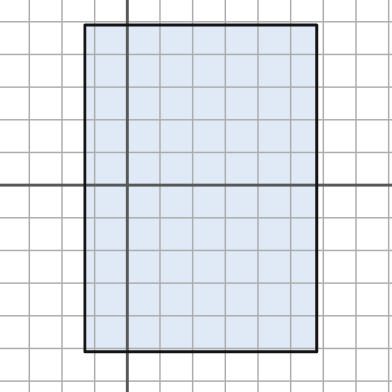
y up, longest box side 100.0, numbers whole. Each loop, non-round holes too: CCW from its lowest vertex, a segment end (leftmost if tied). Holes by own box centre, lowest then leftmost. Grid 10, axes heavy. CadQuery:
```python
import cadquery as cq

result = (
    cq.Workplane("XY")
    .moveTo(-13.0, -51.0)
    .lineTo(58.0, -51.0)
    .lineTo(58.0, 49.0)
    .lineTo(-13.0, 49.0)
    .close()
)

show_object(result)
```